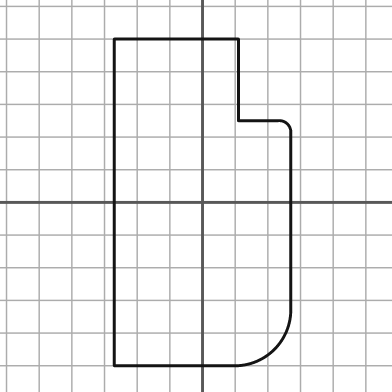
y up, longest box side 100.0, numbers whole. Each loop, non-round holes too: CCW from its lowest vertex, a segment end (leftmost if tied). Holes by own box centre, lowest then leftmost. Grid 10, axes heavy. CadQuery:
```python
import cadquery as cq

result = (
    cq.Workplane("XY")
    .moveTo(-27.0, -50.0)
    .lineTo(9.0, -50.0)
    .threePointArc((22.0, -45.0), (27.0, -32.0))
    .lineTo(27.0, 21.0)
    .threePointArc((26.0, 24.0), (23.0, 25.0))
    .lineTo(11.0, 25.0)
    .lineTo(11.0, 50.0)
    .lineTo(-27.0, 50.0)
    .close()
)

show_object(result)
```